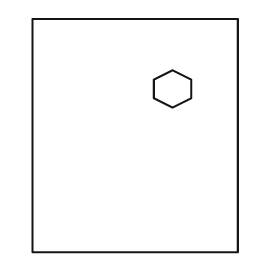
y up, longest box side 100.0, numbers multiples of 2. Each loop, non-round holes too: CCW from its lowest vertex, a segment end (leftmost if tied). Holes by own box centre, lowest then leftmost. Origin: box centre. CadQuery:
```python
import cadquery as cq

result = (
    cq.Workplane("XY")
    .moveTo(-44.0, -50.0)
    .lineTo(44.0, -50.0)
    .lineTo(44.0, 50.0)
    .lineTo(-44.0, 50.0)
    .close()
    .moveTo(16.0, 12.0)
    .lineTo(24.0, 16.0)
    .lineTo(24.0, 24.0)
    .lineTo(16.0, 28.0)
    .lineTo(8.0, 24.0)
    .lineTo(8.0, 16.0)
    .close()
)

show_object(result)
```